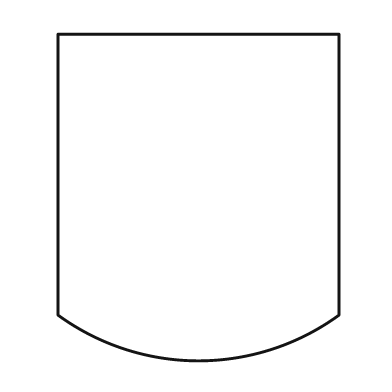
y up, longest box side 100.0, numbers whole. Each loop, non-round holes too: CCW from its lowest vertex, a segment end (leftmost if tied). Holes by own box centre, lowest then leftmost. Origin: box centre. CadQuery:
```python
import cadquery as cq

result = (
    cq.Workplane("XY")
    .moveTo(-43.0, -36.0)
    .threePointArc((0.0, -50.0), (43.0, -36.0))
    .lineTo(43.0, 50.0)
    .lineTo(-43.0, 50.0)
    .close()
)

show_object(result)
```